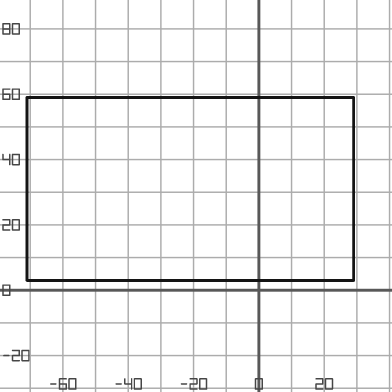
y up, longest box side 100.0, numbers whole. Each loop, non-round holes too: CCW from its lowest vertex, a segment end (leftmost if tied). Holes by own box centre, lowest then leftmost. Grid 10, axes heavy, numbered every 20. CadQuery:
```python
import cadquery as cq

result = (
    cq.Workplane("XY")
    .moveTo(-71.0, 3.0)
    .lineTo(29.0, 3.0)
    .lineTo(29.0, 59.0)
    .lineTo(-71.0, 59.0)
    .close()
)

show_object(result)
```